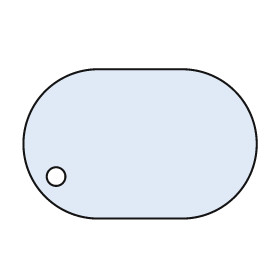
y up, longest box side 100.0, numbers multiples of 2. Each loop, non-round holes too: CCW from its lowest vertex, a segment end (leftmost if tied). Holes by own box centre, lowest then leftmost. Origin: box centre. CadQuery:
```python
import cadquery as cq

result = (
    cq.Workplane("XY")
    .moveTo(-18.0, -32.0)
    .lineTo(18.0, -32.0)
    .threePointArc((50.0, 0.0), (18.0, 32.0))
    .lineTo(-18.0, 32.0)
    .threePointArc((-50.0, 0.0), (-18.0, -32.0))
    .close()
    .moveTo(-36.0, -14.0)
    .circle(4.0)
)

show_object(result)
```